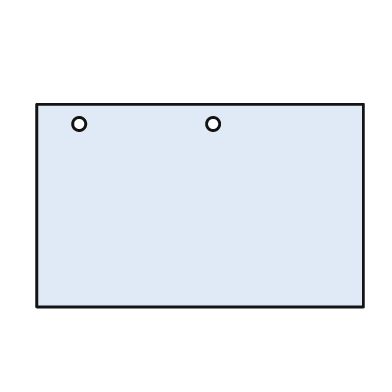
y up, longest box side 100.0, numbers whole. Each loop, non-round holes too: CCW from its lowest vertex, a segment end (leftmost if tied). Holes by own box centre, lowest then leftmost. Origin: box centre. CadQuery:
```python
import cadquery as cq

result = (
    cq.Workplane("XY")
    .moveTo(-50.0, -31.0)
    .lineTo(50.0, -31.0)
    .lineTo(50.0, 31.0)
    .lineTo(-50.0, 31.0)
    .close()
    .moveTo(-37.0, 25.0)
    .circle(2.0)
    .moveTo(4.0, 25.0)
    .circle(2.0)
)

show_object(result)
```